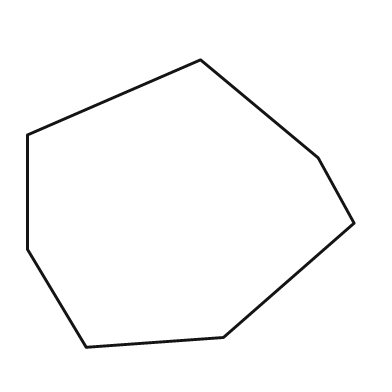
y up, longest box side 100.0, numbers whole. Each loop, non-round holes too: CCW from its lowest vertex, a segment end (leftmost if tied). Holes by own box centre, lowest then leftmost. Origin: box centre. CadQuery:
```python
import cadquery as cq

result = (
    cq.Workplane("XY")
    .moveTo(-32.0, -44.0)
    .lineTo(10.0, -41.0)
    .lineTo(50.0, -6.0)
    .lineTo(39.0, 14.0)
    .lineTo(3.0, 44.0)
    .lineTo(-50.0, 21.0)
    .lineTo(-50.0, -14.0)
    .close()
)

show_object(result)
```